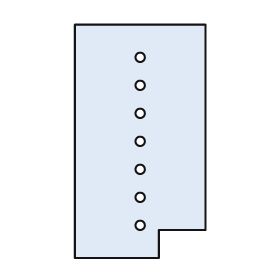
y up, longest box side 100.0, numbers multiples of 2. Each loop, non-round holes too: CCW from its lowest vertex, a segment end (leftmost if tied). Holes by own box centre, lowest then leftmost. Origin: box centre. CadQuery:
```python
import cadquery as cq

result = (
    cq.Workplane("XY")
    .moveTo(-28.0, -50.0)
    .lineTo(8.0, -50.0)
    .lineTo(8.0, -38.0)
    .lineTo(28.0, -38.0)
    .lineTo(28.0, 50.0)
    .lineTo(-28.0, 50.0)
    .close()
    .moveTo(0.0, -36.0)
    .circle(2.0)
    .moveTo(0.0, -24.0)
    .circle(2.0)
    .moveTo(0.0, -12.0)
    .circle(2.0)
    .moveTo(0.0, 0.0)
    .circle(2.0)
    .moveTo(0.0, 12.0)
    .circle(2.0)
    .moveTo(0.0, 24.0)
    .circle(2.0)
    .moveTo(0.0, 36.0)
    .circle(2.0)
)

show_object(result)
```